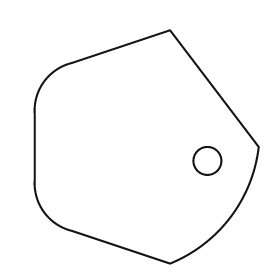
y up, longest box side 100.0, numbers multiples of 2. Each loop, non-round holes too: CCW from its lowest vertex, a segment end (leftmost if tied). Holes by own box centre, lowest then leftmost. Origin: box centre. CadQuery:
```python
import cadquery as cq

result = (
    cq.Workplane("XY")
    .moveTo(10.0, -50.0)
    .threePointArc((36.0, -30.0), (48.0, 0.0))
    .lineTo(10.0, 50.0)
    .lineTo(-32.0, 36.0)
    .threePointArc((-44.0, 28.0), (-48.0, 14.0))
    .lineTo(-48.0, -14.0)
    .threePointArc((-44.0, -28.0), (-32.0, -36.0))
    .close()
    .moveTo(26.0, -6.0)
    .circle(6.0)
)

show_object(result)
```